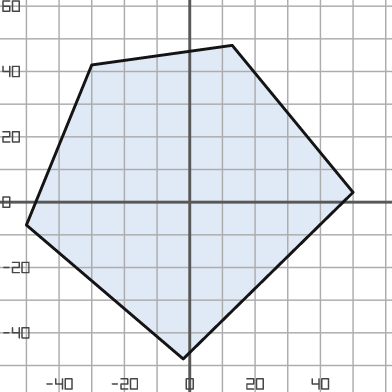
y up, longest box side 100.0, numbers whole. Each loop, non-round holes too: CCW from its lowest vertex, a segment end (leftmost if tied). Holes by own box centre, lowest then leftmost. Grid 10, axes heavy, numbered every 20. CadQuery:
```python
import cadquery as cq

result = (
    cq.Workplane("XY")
    .moveTo(-2.0, -48.0)
    .lineTo(50.0, 3.0)
    .lineTo(13.0, 48.0)
    .lineTo(-30.0, 42.0)
    .lineTo(-50.0, -7.0)
    .close()
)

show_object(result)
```